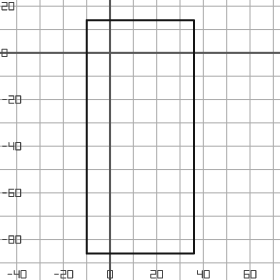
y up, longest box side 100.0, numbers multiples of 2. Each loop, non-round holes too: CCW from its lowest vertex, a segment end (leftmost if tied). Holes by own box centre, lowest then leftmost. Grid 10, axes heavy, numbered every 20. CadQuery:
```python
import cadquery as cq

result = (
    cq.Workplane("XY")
    .moveTo(-10.0, -86.0)
    .lineTo(36.0, -86.0)
    .lineTo(36.0, 14.0)
    .lineTo(-10.0, 14.0)
    .close()
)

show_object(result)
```